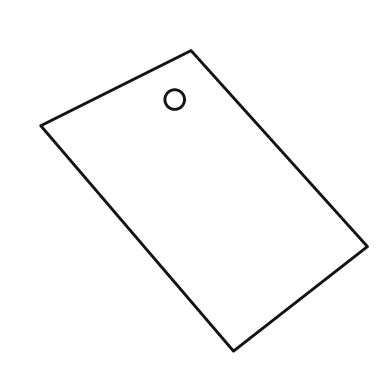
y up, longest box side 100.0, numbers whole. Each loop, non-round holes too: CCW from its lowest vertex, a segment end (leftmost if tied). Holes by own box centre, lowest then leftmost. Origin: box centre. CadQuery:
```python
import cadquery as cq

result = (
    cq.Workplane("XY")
    .moveTo(9.0, -46.0)
    .lineTo(50.0, -14.0)
    .lineTo(-4.0, 46.0)
    .lineTo(-50.0, 23.0)
    .close()
    .moveTo(-9.0, 31.0)
    .circle(3.0)
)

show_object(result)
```